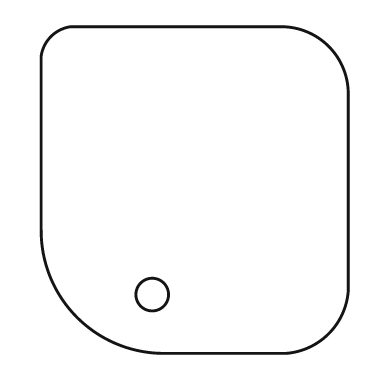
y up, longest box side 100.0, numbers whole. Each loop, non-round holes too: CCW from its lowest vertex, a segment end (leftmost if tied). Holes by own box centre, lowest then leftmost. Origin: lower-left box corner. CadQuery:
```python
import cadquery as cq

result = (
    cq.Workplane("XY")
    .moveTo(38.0, 0.0)
    .lineTo(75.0, 0.0)
    .threePointArc((88.0, 6.0), (94.0, 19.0))
    .lineTo(94.0, 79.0)
    .threePointArc((88.0, 94.0), (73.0, 100.0))
    .lineTo(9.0, 100.0)
    .threePointArc((3.0, 97.0), (0.0, 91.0))
    .lineTo(0.0, 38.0)
    .threePointArc((11.0, 11.0), (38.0, 0.0))
    .close()
    .moveTo(34.0, 18.0)
    .circle(5.0)
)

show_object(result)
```